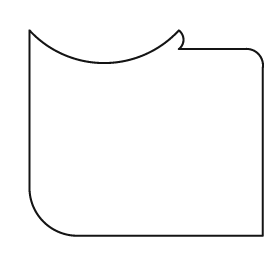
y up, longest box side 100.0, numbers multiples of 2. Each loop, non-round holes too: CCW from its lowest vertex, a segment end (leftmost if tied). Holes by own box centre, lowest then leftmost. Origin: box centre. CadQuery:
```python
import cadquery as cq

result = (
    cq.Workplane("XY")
    .moveTo(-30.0, -44.0)
    .lineTo(50.0, -44.0)
    .lineTo(50.0, 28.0)
    .threePointArc((48.0, 34.0), (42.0, 36.0))
    .lineTo(14.0, 36.0)
    .threePointArc((16.0, 40.0), (14.0, 44.0))
    .threePointArc((-18.0, 30.0), (-50.0, 44.0))
    .lineTo(-50.0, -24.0)
    .threePointArc((-44.0, -38.0), (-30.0, -44.0))
    .close()
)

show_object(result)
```